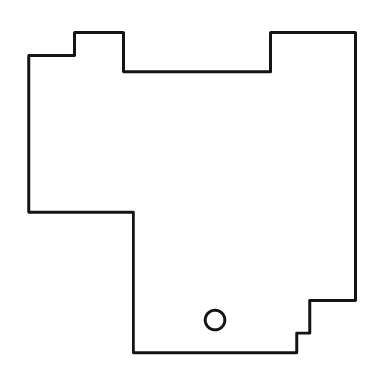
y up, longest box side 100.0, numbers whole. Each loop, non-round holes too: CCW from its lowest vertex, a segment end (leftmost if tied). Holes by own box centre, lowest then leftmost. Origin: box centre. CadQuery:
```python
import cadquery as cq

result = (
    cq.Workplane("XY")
    .moveTo(-18.0, -49.0)
    .lineTo(32.0, -49.0)
    .lineTo(32.0, -43.0)
    .lineTo(36.0, -43.0)
    .lineTo(36.0, -33.0)
    .lineTo(50.0, -33.0)
    .lineTo(50.0, 49.0)
    .lineTo(24.0, 49.0)
    .lineTo(24.0, 37.0)
    .lineTo(-21.0, 37.0)
    .lineTo(-21.0, 49.0)
    .lineTo(-36.0, 49.0)
    .lineTo(-36.0, 42.0)
    .lineTo(-50.0, 42.0)
    .lineTo(-50.0, -6.0)
    .lineTo(-18.0, -6.0)
    .close()
    .moveTo(7.0, -39.0)
    .circle(3.0)
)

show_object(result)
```